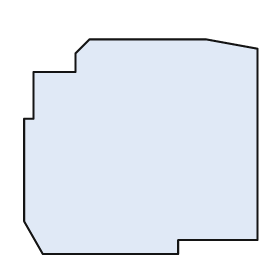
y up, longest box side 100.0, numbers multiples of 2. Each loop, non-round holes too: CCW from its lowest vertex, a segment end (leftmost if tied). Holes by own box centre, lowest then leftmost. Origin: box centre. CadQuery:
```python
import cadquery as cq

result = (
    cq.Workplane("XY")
    .moveTo(-42.0, -46.0)
    .lineTo(16.0, -46.0)
    .lineTo(16.0, -40.0)
    .lineTo(50.0, -40.0)
    .lineTo(50.0, 42.0)
    .lineTo(28.0, 46.0)
    .lineTo(-22.0, 46.0)
    .lineTo(-28.0, 40.0)
    .lineTo(-28.0, 32.0)
    .lineTo(-46.0, 32.0)
    .lineTo(-46.0, 12.0)
    .lineTo(-50.0, 12.0)
    .lineTo(-50.0, -32.0)
    .close()
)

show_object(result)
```